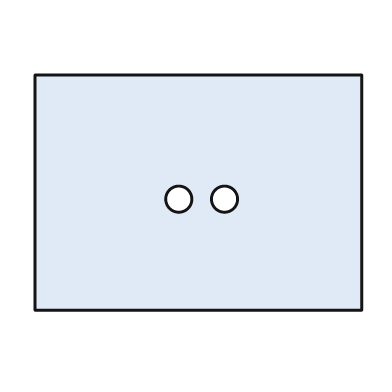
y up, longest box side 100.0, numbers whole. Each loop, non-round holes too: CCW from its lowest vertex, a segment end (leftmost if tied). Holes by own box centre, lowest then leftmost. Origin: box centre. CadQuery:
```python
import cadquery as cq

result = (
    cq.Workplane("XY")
    .moveTo(-50.0, -36.0)
    .lineTo(50.0, -36.0)
    .lineTo(50.0, 36.0)
    .lineTo(-50.0, 36.0)
    .close()
    .moveTo(-6.0, -2.0)
    .circle(4.0)
    .moveTo(8.0, -2.0)
    .circle(4.0)
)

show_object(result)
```